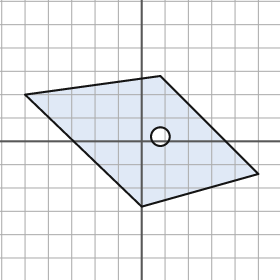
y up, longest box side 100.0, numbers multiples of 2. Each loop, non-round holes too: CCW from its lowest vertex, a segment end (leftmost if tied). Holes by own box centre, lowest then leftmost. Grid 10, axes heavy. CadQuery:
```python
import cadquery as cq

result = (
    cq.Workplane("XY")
    .moveTo(0.0, -28.0)
    .lineTo(50.0, -14.0)
    .lineTo(8.0, 28.0)
    .lineTo(-50.0, 20.0)
    .close()
    .moveTo(8.0, 2.0)
    .circle(4.0)
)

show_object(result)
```